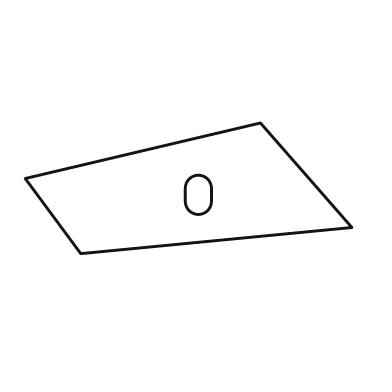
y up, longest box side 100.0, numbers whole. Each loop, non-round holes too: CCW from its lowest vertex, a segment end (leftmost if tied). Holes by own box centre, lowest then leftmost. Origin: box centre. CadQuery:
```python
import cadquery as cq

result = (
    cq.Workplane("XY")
    .moveTo(-33.0, -20.0)
    .lineTo(50.0, -12.0)
    .lineTo(22.0, 20.0)
    .lineTo(-50.0, 3.0)
    .close()
    .moveTo(-1.0, -4.0)
    .threePointArc((3.0, -8.0), (7.0, -4.0))
    .lineTo(7.0, 0.0)
    .threePointArc((3.0, 4.0), (-1.0, 0.0))
    .close()
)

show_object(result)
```